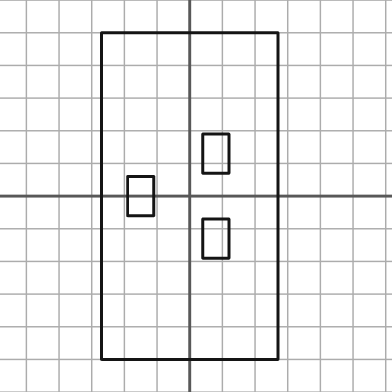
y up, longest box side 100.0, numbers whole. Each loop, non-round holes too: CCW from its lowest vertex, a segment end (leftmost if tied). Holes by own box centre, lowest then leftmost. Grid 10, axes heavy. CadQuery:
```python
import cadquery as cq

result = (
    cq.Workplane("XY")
    .moveTo(-27.0, -50.0)
    .lineTo(27.0, -50.0)
    .lineTo(27.0, 50.0)
    .lineTo(-27.0, 50.0)
    .close()
    .moveTo(4.0, -19.0)
    .lineTo(12.0, -19.0)
    .lineTo(12.0, -7.0)
    .lineTo(4.0, -7.0)
    .close()
    .moveTo(-19.0, -6.0)
    .lineTo(-11.0, -6.0)
    .lineTo(-11.0, 6.0)
    .lineTo(-19.0, 6.0)
    .close()
    .moveTo(4.0, 7.0)
    .lineTo(12.0, 7.0)
    .lineTo(12.0, 19.0)
    .lineTo(4.0, 19.0)
    .close()
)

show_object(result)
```